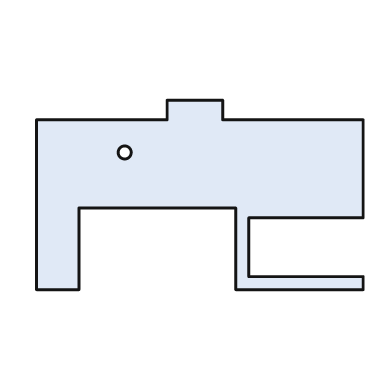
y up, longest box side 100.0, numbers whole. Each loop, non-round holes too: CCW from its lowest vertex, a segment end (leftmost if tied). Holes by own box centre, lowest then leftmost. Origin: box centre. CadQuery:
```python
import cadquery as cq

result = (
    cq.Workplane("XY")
    .moveTo(-50.0, -29.0)
    .lineTo(-37.0, -29.0)
    .lineTo(-37.0, -4.0)
    .lineTo(11.0, -4.0)
    .lineTo(11.0, -29.0)
    .lineTo(50.0, -29.0)
    .lineTo(50.0, -25.0)
    .lineTo(15.0, -25.0)
    .lineTo(15.0, -7.0)
    .lineTo(50.0, -7.0)
    .lineTo(50.0, 23.0)
    .lineTo(7.0, 23.0)
    .lineTo(7.0, 29.0)
    .lineTo(-10.0, 29.0)
    .lineTo(-10.0, 23.0)
    .lineTo(-50.0, 23.0)
    .close()
    .moveTo(-23.0, 13.0)
    .circle(2.0)
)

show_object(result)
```